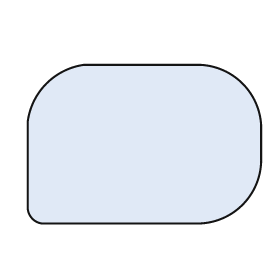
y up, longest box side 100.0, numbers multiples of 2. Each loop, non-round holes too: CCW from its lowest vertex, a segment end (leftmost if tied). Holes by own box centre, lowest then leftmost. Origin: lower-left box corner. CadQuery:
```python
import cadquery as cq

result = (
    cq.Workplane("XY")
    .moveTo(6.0, 0.0)
    .lineTo(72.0, 0.0)
    .threePointArc((92.0, 8.0), (100.0, 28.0))
    .lineTo(100.0, 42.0)
    .threePointArc((92.0, 60.0), (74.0, 68.0))
    .lineTo(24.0, 68.0)
    .threePointArc((8.0, 60.0), (0.0, 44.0))
    .lineTo(0.0, 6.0)
    .threePointArc((2.0, 2.0), (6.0, 0.0))
    .close()
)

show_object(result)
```